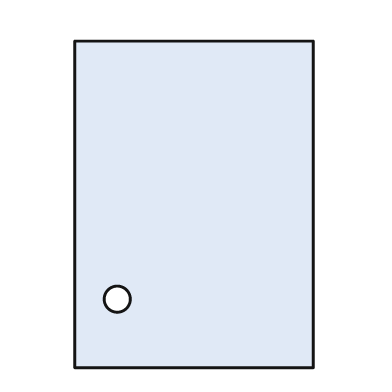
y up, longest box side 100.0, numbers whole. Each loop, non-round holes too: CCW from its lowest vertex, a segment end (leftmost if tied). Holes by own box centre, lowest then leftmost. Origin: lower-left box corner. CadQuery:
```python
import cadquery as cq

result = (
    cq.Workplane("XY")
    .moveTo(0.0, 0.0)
    .lineTo(73.0, 0.0)
    .lineTo(73.0, 100.0)
    .lineTo(0.0, 100.0)
    .close()
    .moveTo(13.0, 21.0)
    .circle(4.0)
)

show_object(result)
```